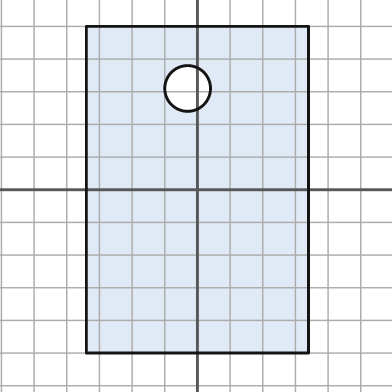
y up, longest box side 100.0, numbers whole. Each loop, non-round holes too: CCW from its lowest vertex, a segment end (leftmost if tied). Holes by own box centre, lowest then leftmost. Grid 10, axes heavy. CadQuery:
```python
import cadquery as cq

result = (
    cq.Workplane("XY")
    .moveTo(-34.0, -50.0)
    .lineTo(34.0, -50.0)
    .lineTo(34.0, 50.0)
    .lineTo(-34.0, 50.0)
    .close()
    .moveTo(-3.0, 31.0)
    .circle(7.0)
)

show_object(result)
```